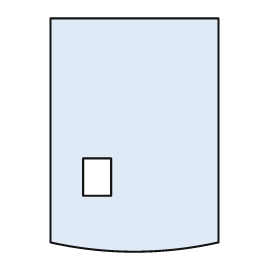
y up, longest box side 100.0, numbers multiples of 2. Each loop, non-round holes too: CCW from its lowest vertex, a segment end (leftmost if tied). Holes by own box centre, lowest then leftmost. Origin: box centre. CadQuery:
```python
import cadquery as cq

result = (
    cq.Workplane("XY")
    .moveTo(-36.0, -46.0)
    .threePointArc((0.0, -50.0), (36.0, -46.0))
    .lineTo(36.0, 50.0)
    .lineTo(-36.0, 50.0)
    .close()
    .moveTo(-22.0, -26.0)
    .lineTo(-10.0, -26.0)
    .lineTo(-10.0, -10.0)
    .lineTo(-22.0, -10.0)
    .close()
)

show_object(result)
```